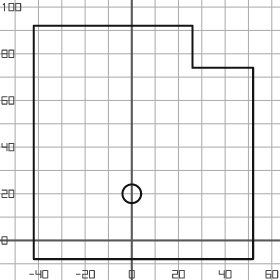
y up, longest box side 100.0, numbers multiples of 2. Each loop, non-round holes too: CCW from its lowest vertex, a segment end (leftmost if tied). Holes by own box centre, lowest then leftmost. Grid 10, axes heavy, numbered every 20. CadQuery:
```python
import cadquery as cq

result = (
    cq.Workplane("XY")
    .moveTo(-42.0, -8.0)
    .lineTo(52.0, -8.0)
    .lineTo(52.0, 74.0)
    .lineTo(26.0, 74.0)
    .lineTo(26.0, 92.0)
    .lineTo(-42.0, 92.0)
    .close()
    .moveTo(0.0, 20.0)
    .circle(4.0)
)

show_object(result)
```